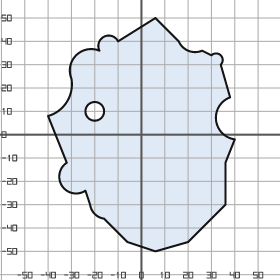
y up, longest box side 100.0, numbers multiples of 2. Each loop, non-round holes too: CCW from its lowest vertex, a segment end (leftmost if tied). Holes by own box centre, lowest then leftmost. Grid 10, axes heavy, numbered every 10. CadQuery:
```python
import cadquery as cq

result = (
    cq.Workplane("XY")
    .moveTo(6.0, -50.0)
    .lineTo(20.0, -46.0)
    .lineTo(36.0, -30.0)
    .lineTo(36.0, -12.0)
    .lineTo(40.0, -2.0)
    .threePointArc((32.0, 6.0), (38.0, 16.0))
    .lineTo(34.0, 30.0)
    .threePointArc((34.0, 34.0), (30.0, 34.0))
    .lineTo(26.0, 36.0)
    .threePointArc((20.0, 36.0), (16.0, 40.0))
    .lineTo(6.0, 50.0)
    .lineTo(-10.0, 40.0)
    .threePointArc((-16.0, 42.0), (-18.0, 36.0))
    .threePointArc((-28.0, 34.0), (-30.0, 24.0))
    .threePointArc((-32.0, 14.0), (-40.0, 8.0))
    .lineTo(-32.0, -12.0)
    .threePointArc((-34.0, -22.0), (-24.0, -24.0))
    .lineTo(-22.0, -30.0)
    .threePointArc((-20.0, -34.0), (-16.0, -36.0))
    .lineTo(-6.0, -46.0)
    .close()
    .moveTo(-20.0, 10.0)
    .circle(4.0)
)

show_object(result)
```